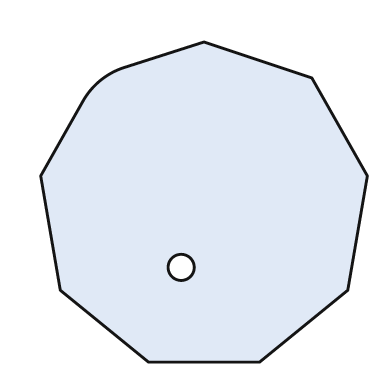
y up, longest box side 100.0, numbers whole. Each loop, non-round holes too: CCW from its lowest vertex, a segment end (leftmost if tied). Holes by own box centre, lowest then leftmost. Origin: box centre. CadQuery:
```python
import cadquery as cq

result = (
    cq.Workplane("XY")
    .moveTo(-17.0, -49.0)
    .lineTo(17.0, -49.0)
    .lineTo(44.0, -27.0)
    .lineTo(50.0, 8.0)
    .lineTo(33.0, 38.0)
    .lineTo(0.0, 49.0)
    .lineTo(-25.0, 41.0)
    .threePointArc((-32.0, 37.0), (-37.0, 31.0))
    .lineTo(-50.0, 8.0)
    .lineTo(-44.0, -27.0)
    .close()
    .moveTo(-7.0, -20.0)
    .circle(4.0)
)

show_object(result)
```